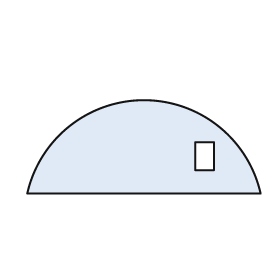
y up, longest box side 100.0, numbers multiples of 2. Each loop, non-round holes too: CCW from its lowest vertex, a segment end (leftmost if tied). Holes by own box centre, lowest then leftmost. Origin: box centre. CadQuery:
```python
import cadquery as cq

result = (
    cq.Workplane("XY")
    .moveTo(-50.0, -20.0)
    .lineTo(50.0, -20.0)
    .threePointArc((0.0, 20.0), (-50.0, -20.0))
    .close()
    .moveTo(22.0, -10.0)
    .lineTo(30.0, -10.0)
    .lineTo(30.0, 2.0)
    .lineTo(22.0, 2.0)
    .close()
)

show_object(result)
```